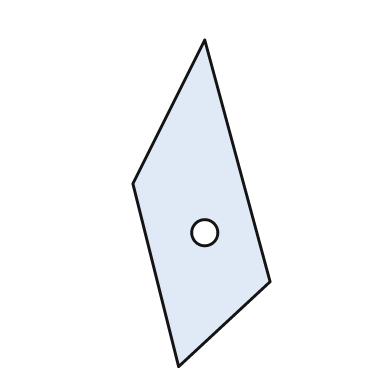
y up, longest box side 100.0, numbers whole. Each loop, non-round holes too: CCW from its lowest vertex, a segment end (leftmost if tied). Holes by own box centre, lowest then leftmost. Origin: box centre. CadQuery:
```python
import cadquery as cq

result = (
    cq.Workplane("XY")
    .moveTo(-7.0, -50.0)
    .lineTo(21.0, -24.0)
    .lineTo(1.0, 50.0)
    .lineTo(-21.0, 6.0)
    .close()
    .moveTo(1.0, -9.0)
    .circle(4.0)
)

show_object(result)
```